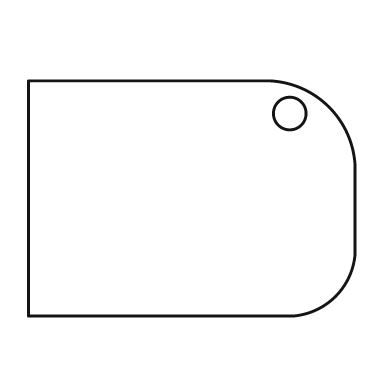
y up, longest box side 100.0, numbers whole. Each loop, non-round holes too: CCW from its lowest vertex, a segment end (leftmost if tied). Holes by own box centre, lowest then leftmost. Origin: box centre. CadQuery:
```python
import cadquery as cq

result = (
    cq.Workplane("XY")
    .moveTo(-50.0, -36.0)
    .lineTo(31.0, -36.0)
    .threePointArc((44.0, -30.0), (50.0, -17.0))
    .lineTo(50.0, 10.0)
    .threePointArc((42.0, 28.0), (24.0, 36.0))
    .lineTo(-50.0, 36.0)
    .close()
    .moveTo(30.0, 26.0)
    .circle(5.0)
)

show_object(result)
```